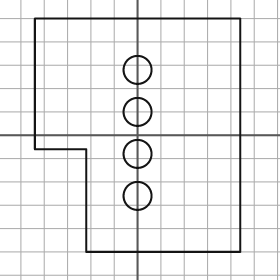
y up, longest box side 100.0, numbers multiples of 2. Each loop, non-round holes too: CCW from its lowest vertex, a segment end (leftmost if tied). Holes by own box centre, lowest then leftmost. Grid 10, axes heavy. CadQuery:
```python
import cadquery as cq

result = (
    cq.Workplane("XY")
    .moveTo(-22.0, -50.0)
    .lineTo(44.0, -50.0)
    .lineTo(44.0, 50.0)
    .lineTo(-44.0, 50.0)
    .lineTo(-44.0, -6.0)
    .lineTo(-22.0, -6.0)
    .close()
    .moveTo(0.0, -26.0)
    .circle(6.0)
    .moveTo(0.0, -8.0)
    .circle(6.0)
    .moveTo(0.0, 10.0)
    .circle(6.0)
    .moveTo(0.0, 28.0)
    .circle(6.0)
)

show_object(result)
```